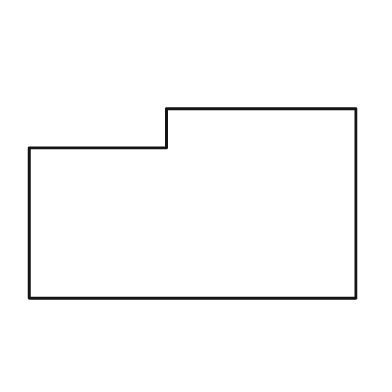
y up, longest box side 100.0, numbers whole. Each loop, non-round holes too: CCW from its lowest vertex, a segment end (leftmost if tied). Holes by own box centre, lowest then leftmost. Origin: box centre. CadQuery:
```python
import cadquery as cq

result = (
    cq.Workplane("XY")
    .moveTo(-50.0, -29.0)
    .lineTo(50.0, -29.0)
    .lineTo(50.0, 29.0)
    .lineTo(-8.0, 29.0)
    .lineTo(-8.0, 17.0)
    .lineTo(-50.0, 17.0)
    .close()
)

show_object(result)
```